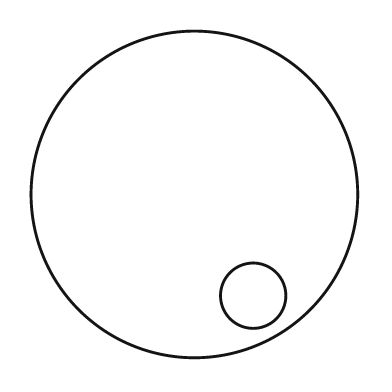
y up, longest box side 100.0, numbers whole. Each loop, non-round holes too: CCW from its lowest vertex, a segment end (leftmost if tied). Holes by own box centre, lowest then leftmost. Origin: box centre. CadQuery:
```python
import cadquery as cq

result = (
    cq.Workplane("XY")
    .moveTo(0.0, 0.0)
    .circle(50.0)
    .moveTo(18.0, -31.0)
    .circle(10.0)
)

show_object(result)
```